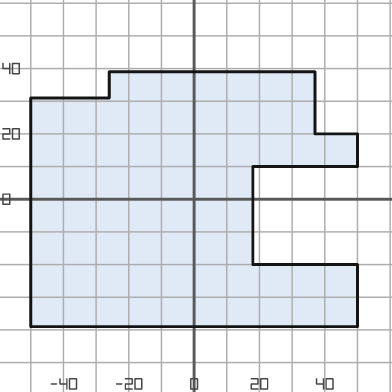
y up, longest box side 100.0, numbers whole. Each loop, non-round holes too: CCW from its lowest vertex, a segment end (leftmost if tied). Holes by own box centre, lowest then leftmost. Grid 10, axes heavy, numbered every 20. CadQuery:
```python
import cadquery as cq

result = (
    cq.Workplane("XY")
    .moveTo(-50.0, -39.0)
    .lineTo(50.0, -39.0)
    .lineTo(50.0, -20.0)
    .lineTo(18.0, -20.0)
    .lineTo(18.0, 10.0)
    .lineTo(50.0, 10.0)
    .lineTo(50.0, 20.0)
    .lineTo(37.0, 20.0)
    .lineTo(37.0, 39.0)
    .lineTo(-26.0, 39.0)
    .lineTo(-26.0, 31.0)
    .lineTo(-50.0, 31.0)
    .close()
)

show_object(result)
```